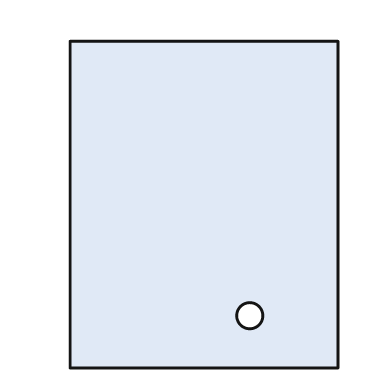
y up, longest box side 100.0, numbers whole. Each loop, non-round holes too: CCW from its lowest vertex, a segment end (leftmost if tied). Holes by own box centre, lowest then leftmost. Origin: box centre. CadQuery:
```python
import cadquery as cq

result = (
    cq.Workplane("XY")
    .moveTo(-41.0, -50.0)
    .lineTo(41.0, -50.0)
    .lineTo(41.0, 50.0)
    .lineTo(-41.0, 50.0)
    .close()
    .moveTo(14.0, -34.0)
    .circle(4.0)
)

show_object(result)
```